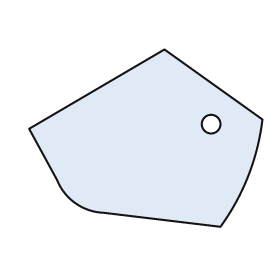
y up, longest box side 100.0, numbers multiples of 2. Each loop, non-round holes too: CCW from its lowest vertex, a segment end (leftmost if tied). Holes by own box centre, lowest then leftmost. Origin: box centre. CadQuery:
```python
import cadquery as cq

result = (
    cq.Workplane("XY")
    .moveTo(32.0, -38.0)
    .threePointArc((44.0, -16.0), (50.0, 8.0))
    .lineTo(8.0, 38.0)
    .lineTo(-50.0, 4.0)
    .lineTo(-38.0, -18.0)
    .threePointArc((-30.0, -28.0), (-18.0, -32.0))
    .close()
    .moveTo(28.0, 6.0)
    .circle(4.0)
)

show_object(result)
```